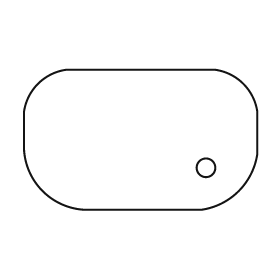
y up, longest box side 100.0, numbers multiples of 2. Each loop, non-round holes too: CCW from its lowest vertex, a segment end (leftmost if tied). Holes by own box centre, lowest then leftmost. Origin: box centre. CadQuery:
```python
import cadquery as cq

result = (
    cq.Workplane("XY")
    .moveTo(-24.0, -30.0)
    .lineTo(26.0, -30.0)
    .threePointArc((42.0, -22.0), (50.0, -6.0))
    .lineTo(50.0, 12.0)
    .threePointArc((44.0, 24.0), (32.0, 30.0))
    .lineTo(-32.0, 30.0)
    .threePointArc((-44.0, 24.0), (-50.0, 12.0))
    .lineTo(-50.0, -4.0)
    .threePointArc((-42.0, -22.0), (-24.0, -30.0))
    .close()
    .moveTo(28.0, -12.0)
    .circle(4.0)
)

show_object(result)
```